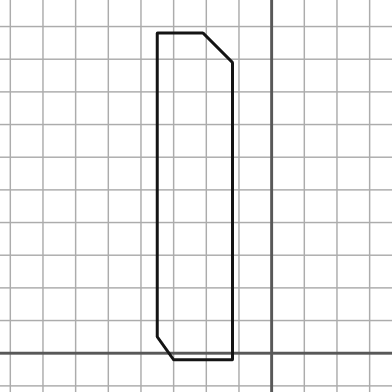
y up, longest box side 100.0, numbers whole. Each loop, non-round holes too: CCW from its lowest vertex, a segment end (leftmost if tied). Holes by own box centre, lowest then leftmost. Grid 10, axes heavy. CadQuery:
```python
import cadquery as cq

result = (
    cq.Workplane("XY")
    .moveTo(-30.0, -2.0)
    .lineTo(-12.0, -2.0)
    .lineTo(-12.0, 89.0)
    .lineTo(-21.0, 98.0)
    .lineTo(-35.0, 98.0)
    .lineTo(-35.0, 5.0)
    .close()
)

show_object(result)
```